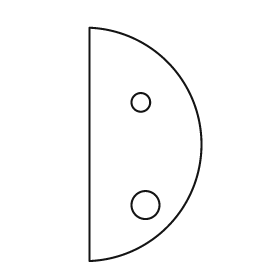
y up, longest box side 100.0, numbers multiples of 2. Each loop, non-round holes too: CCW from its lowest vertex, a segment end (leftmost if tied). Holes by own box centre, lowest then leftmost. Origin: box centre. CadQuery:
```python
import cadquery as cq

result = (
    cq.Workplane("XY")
    .moveTo(-24.0, -50.0)
    .threePointArc((24.0, 0.0), (-24.0, 50.0))
    .close()
    .moveTo(0.0, -26.0)
    .circle(6.0)
    .moveTo(-2.0, 18.0)
    .circle(4.0)
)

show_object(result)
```